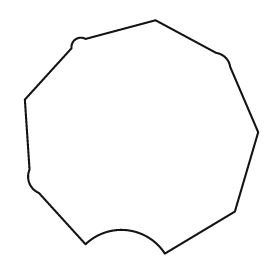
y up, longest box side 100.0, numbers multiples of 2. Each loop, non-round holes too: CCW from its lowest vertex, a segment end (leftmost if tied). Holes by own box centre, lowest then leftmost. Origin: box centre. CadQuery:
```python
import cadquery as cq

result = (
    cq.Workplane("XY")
    .moveTo(10.0, -50.0)
    .lineTo(40.0, -32.0)
    .lineTo(50.0, 2.0)
    .lineTo(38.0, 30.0)
    .threePointArc((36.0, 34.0), (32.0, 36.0))
    .lineTo(6.0, 50.0)
    .lineTo(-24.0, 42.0)
    .threePointArc((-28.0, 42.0), (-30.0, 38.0))
    .lineTo(-50.0, 16.0)
    .lineTo(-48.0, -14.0)
    .threePointArc((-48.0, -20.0), (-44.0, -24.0))
    .lineTo(-24.0, -46.0)
    .threePointArc((-6.0, -40.0), (10.0, -50.0))
    .close()
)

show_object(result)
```